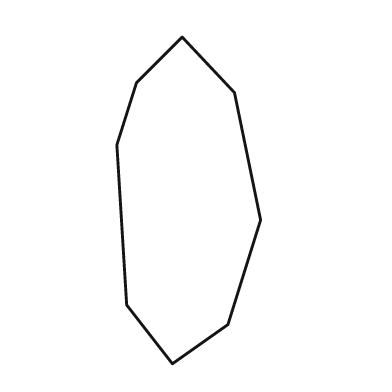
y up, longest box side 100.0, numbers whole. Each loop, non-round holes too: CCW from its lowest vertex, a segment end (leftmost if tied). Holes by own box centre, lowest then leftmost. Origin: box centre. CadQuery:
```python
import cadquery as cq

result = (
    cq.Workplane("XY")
    .moveTo(-5.0, -50.0)
    .lineTo(12.0, -38.0)
    .lineTo(22.0, -6.0)
    .lineTo(14.0, 33.0)
    .lineTo(-2.0, 50.0)
    .lineTo(-16.0, 36.0)
    .lineTo(-22.0, 17.0)
    .lineTo(-19.0, -32.0)
    .close()
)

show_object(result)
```